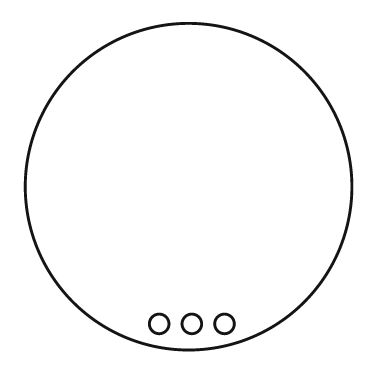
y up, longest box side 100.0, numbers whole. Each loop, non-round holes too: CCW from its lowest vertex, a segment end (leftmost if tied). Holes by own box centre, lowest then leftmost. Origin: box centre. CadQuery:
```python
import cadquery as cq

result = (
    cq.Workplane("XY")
    .moveTo(0.0, 0.0)
    .circle(50.0)
    .moveTo(-9.0, -42.0)
    .circle(3.0)
    .moveTo(1.0, -42.0)
    .circle(3.0)
    .moveTo(11.0, -42.0)
    .circle(3.0)
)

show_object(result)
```